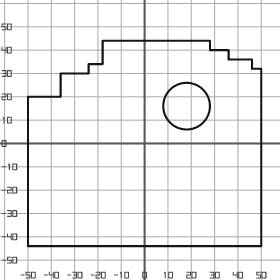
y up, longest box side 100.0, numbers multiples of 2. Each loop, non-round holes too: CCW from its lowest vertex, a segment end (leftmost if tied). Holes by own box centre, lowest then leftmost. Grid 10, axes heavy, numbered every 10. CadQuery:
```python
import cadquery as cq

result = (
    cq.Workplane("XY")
    .moveTo(-50.0, -44.0)
    .lineTo(50.0, -44.0)
    .lineTo(50.0, 32.0)
    .lineTo(46.0, 32.0)
    .lineTo(46.0, 36.0)
    .lineTo(36.0, 36.0)
    .lineTo(36.0, 40.0)
    .lineTo(28.0, 40.0)
    .lineTo(28.0, 44.0)
    .lineTo(-18.0, 44.0)
    .lineTo(-18.0, 34.0)
    .lineTo(-24.0, 34.0)
    .lineTo(-24.0, 30.0)
    .lineTo(-36.0, 30.0)
    .lineTo(-36.0, 20.0)
    .lineTo(-50.0, 20.0)
    .close()
    .moveTo(18.0, 16.0)
    .circle(10.0)
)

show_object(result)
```